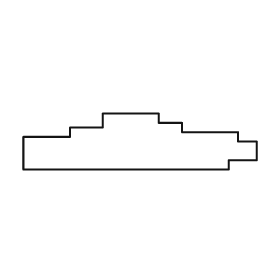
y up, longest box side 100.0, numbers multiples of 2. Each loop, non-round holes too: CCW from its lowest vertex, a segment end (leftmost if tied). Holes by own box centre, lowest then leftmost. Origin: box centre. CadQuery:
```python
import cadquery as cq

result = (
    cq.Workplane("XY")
    .moveTo(-50.0, -12.0)
    .lineTo(38.0, -12.0)
    .lineTo(38.0, -8.0)
    .lineTo(50.0, -8.0)
    .lineTo(50.0, 0.0)
    .lineTo(42.0, 0.0)
    .lineTo(42.0, 4.0)
    .lineTo(18.0, 4.0)
    .lineTo(18.0, 8.0)
    .lineTo(8.0, 8.0)
    .lineTo(8.0, 12.0)
    .lineTo(-16.0, 12.0)
    .lineTo(-16.0, 6.0)
    .lineTo(-30.0, 6.0)
    .lineTo(-30.0, 2.0)
    .lineTo(-50.0, 2.0)
    .close()
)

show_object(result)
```